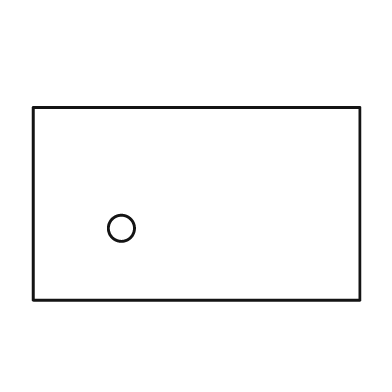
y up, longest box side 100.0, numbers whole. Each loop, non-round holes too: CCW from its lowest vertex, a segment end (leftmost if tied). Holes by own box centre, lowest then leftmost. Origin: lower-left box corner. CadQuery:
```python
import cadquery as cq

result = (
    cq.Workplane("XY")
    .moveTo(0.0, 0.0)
    .lineTo(100.0, 0.0)
    .lineTo(100.0, 59.0)
    .lineTo(0.0, 59.0)
    .close()
    .moveTo(27.0, 22.0)
    .circle(4.0)
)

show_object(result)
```